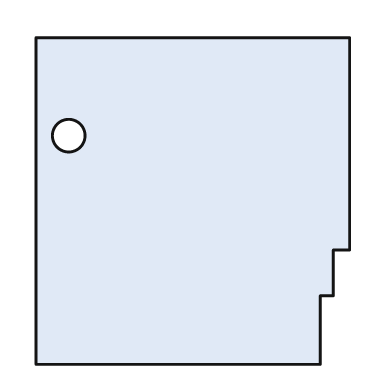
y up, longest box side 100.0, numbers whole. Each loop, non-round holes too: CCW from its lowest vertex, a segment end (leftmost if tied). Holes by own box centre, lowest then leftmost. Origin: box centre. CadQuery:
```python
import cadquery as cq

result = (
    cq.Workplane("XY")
    .moveTo(-48.0, -50.0)
    .lineTo(39.0, -50.0)
    .lineTo(39.0, -29.0)
    .lineTo(43.0, -29.0)
    .lineTo(43.0, -15.0)
    .lineTo(48.0, -15.0)
    .lineTo(48.0, 50.0)
    .lineTo(-48.0, 50.0)
    .close()
    .moveTo(-38.0, 20.0)
    .circle(5.0)
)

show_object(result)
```